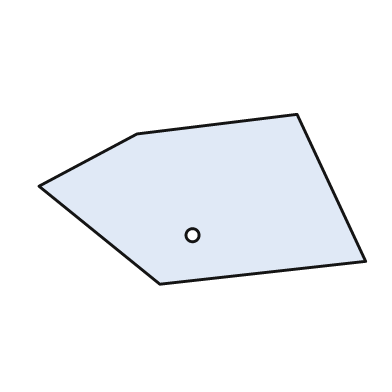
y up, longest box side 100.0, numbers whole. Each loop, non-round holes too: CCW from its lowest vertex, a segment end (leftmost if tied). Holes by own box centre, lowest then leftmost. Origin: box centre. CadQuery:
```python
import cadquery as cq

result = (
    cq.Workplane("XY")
    .moveTo(-13.0, -26.0)
    .lineTo(50.0, -19.0)
    .lineTo(29.0, 26.0)
    .lineTo(-20.0, 20.0)
    .lineTo(-50.0, 4.0)
    .close()
    .moveTo(-3.0, -11.0)
    .circle(2.0)
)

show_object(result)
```